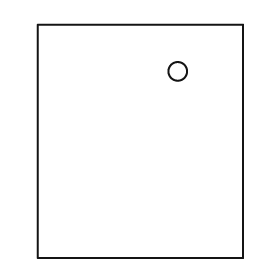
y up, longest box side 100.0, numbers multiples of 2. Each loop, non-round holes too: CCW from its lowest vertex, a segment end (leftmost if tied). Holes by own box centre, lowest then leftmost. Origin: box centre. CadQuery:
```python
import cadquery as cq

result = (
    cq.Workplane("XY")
    .moveTo(-44.0, -50.0)
    .lineTo(44.0, -50.0)
    .lineTo(44.0, 50.0)
    .lineTo(-44.0, 50.0)
    .close()
    .moveTo(16.0, 30.0)
    .circle(4.0)
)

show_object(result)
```